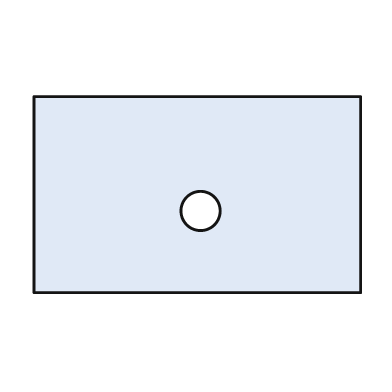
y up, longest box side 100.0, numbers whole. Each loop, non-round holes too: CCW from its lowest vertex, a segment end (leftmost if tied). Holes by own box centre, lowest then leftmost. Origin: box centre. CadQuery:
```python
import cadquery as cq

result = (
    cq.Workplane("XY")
    .moveTo(-50.0, -30.0)
    .lineTo(50.0, -30.0)
    .lineTo(50.0, 30.0)
    .lineTo(-50.0, 30.0)
    .close()
    .moveTo(1.0, -5.0)
    .circle(6.0)
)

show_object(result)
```